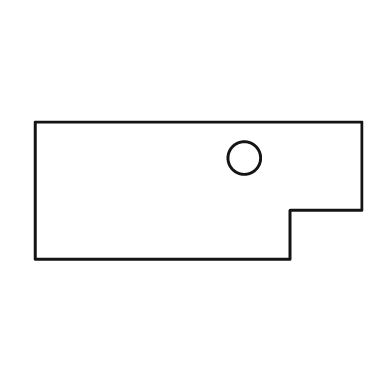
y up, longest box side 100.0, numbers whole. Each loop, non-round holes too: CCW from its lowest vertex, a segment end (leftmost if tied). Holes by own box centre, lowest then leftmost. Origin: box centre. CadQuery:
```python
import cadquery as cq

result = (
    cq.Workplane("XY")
    .moveTo(-50.0, -21.0)
    .lineTo(28.0, -21.0)
    .lineTo(28.0, -6.0)
    .lineTo(50.0, -6.0)
    .lineTo(50.0, 21.0)
    .lineTo(-50.0, 21.0)
    .close()
    .moveTo(14.0, 10.0)
    .circle(5.0)
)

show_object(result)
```